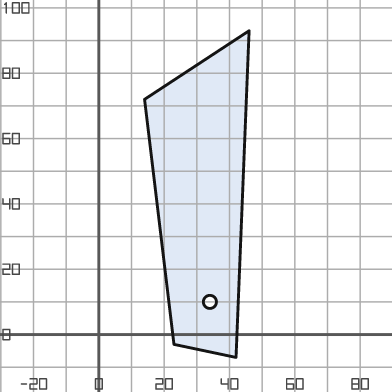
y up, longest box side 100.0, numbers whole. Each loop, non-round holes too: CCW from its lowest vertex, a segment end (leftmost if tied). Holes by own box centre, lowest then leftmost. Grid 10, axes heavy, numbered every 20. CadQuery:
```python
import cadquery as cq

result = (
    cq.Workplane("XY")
    .moveTo(42.0, -7.0)
    .lineTo(46.0, 93.0)
    .lineTo(14.0, 72.0)
    .lineTo(23.0, -3.0)
    .close()
    .moveTo(34.0, 10.0)
    .circle(2.0)
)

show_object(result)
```